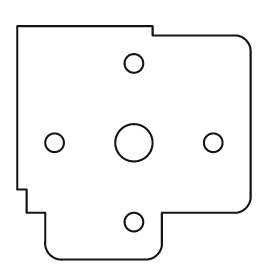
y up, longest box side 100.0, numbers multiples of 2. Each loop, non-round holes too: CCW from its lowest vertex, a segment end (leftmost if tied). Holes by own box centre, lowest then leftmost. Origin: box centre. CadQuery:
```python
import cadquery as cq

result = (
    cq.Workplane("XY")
    .moveTo(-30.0, -50.0)
    .lineTo(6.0, -50.0)
    .threePointArc((10.0, -48.0), (12.0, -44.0))
    .lineTo(12.0, -30.0)
    .lineTo(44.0, -30.0)
    .threePointArc((48.0, -28.0), (50.0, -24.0))
    .lineTo(50.0, 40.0)
    .threePointArc((48.0, 44.0), (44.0, 46.0))
    .lineTo(8.0, 46.0)
    .lineTo(8.0, 50.0)
    .lineTo(-50.0, 50.0)
    .lineTo(-50.0, -20.0)
    .lineTo(-46.0, -20.0)
    .lineTo(-46.0, -30.0)
    .lineTo(-38.0, -30.0)
    .lineTo(-38.0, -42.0)
    .threePointArc((-36.0, -48.0), (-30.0, -50.0))
    .close()
    .moveTo(0.0, -34.0)
    .circle(4.0)
    .moveTo(-34.0, 0.0)
    .circle(4.0)
    .moveTo(0.0, 0.0)
    .circle(8.0)
    .moveTo(34.0, 0.0)
    .circle(4.0)
    .moveTo(0.0, 34.0)
    .circle(4.0)
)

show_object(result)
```